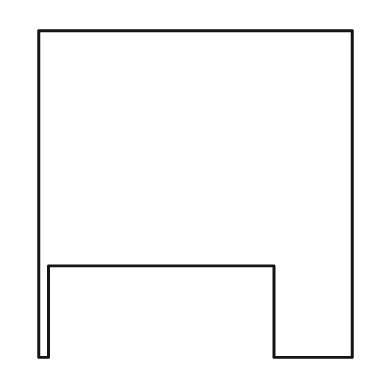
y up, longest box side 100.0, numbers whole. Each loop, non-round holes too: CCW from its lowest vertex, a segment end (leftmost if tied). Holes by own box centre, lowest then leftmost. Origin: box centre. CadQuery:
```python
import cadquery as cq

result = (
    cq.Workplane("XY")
    .moveTo(-48.0, -50.0)
    .lineTo(-45.0, -50.0)
    .lineTo(-45.0, -22.0)
    .lineTo(24.0, -22.0)
    .lineTo(24.0, -50.0)
    .lineTo(48.0, -50.0)
    .lineTo(48.0, 50.0)
    .lineTo(-48.0, 50.0)
    .close()
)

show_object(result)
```